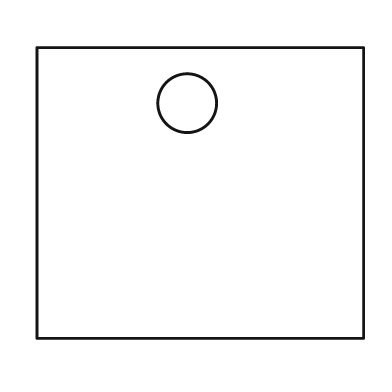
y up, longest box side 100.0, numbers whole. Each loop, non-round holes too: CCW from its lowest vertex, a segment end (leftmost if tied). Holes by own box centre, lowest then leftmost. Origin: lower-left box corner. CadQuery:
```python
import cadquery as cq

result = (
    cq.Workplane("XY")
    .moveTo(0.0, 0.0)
    .lineTo(100.0, 0.0)
    .lineTo(100.0, 89.0)
    .lineTo(0.0, 89.0)
    .close()
    .moveTo(46.0, 72.0)
    .circle(9.0)
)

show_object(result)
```